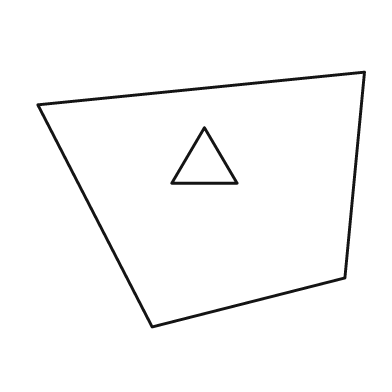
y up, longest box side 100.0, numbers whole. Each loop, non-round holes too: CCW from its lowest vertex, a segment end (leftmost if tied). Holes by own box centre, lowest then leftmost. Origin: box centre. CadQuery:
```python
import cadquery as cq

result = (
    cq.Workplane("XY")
    .moveTo(-15.0, -39.0)
    .lineTo(44.0, -24.0)
    .lineTo(50.0, 39.0)
    .lineTo(-50.0, 29.0)
    .close()
    .moveTo(-9.0, 5.0)
    .lineTo(11.0, 5.0)
    .lineTo(1.0, 22.0)
    .close()
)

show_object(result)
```